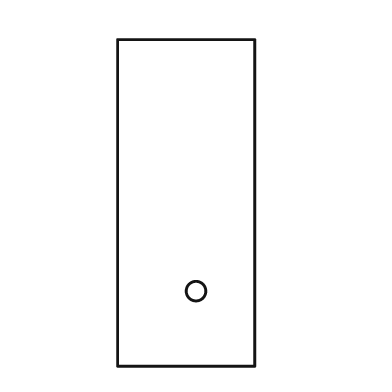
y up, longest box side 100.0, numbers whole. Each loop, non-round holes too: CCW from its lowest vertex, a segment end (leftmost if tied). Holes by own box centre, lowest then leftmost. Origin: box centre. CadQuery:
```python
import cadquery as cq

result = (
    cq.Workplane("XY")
    .moveTo(-21.0, -50.0)
    .lineTo(21.0, -50.0)
    .lineTo(21.0, 50.0)
    .lineTo(-21.0, 50.0)
    .close()
    .moveTo(3.0, -27.0)
    .circle(3.0)
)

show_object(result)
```